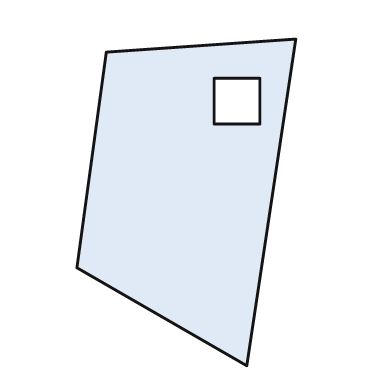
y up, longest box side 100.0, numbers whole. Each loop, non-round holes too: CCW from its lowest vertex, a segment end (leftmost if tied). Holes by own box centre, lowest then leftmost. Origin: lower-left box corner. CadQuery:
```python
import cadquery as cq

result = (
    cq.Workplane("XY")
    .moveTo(52.0, 0.0)
    .lineTo(67.0, 100.0)
    .lineTo(9.0, 96.0)
    .lineTo(0.0, 30.0)
    .close()
    .moveTo(42.0, 74.0)
    .lineTo(56.0, 74.0)
    .lineTo(56.0, 88.0)
    .lineTo(42.0, 88.0)
    .close()
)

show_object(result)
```